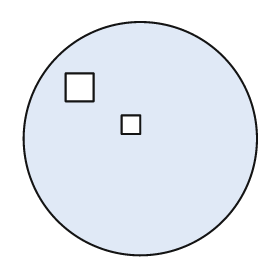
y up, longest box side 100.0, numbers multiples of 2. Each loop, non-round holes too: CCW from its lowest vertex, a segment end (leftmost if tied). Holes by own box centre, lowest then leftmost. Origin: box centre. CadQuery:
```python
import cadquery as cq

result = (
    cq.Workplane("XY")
    .moveTo(0.0, 0.0)
    .circle(50.0)
    .moveTo(-8.0, 2.0)
    .lineTo(0.0, 2.0)
    .lineTo(0.0, 10.0)
    .lineTo(-8.0, 10.0)
    .close()
    .moveTo(-32.0, 16.0)
    .lineTo(-20.0, 16.0)
    .lineTo(-20.0, 28.0)
    .lineTo(-32.0, 28.0)
    .close()
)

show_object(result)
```